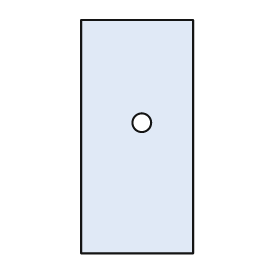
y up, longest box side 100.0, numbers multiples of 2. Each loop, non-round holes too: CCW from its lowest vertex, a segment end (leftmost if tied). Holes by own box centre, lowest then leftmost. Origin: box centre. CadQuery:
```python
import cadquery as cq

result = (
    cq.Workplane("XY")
    .moveTo(-24.0, -50.0)
    .lineTo(24.0, -50.0)
    .lineTo(24.0, 50.0)
    .lineTo(-24.0, 50.0)
    .close()
    .moveTo(2.0, 6.0)
    .circle(4.0)
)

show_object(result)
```